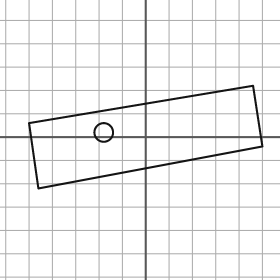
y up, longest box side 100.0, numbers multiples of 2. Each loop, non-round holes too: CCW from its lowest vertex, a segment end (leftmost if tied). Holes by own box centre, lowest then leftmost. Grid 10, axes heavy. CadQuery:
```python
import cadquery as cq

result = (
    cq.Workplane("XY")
    .moveTo(-46.0, -22.0)
    .lineTo(50.0, -4.0)
    .lineTo(46.0, 22.0)
    .lineTo(-50.0, 6.0)
    .close()
    .moveTo(-18.0, 2.0)
    .circle(4.0)
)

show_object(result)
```